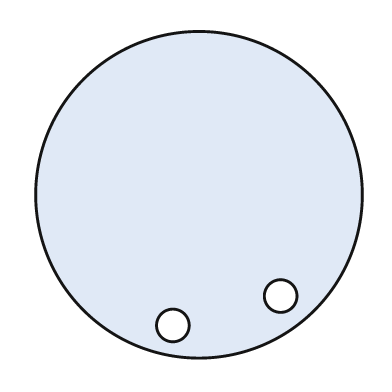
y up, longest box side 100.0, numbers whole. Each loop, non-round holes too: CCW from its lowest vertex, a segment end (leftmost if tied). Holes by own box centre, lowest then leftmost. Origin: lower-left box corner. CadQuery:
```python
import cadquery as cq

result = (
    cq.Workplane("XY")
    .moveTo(50.0, 50.0)
    .circle(50.0)
    .moveTo(42.0, 10.0)
    .circle(5.0)
    .moveTo(75.0, 19.0)
    .circle(5.0)
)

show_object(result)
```